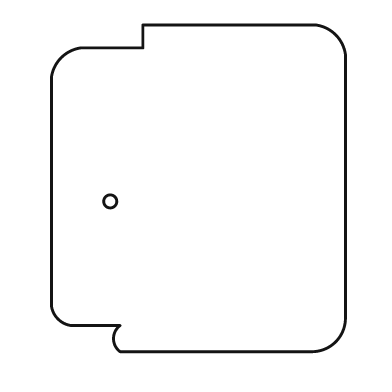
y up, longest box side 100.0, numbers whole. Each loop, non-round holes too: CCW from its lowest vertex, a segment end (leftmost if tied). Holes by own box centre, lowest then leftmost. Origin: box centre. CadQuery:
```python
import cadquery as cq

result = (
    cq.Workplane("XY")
    .moveTo(-24.0, -50.0)
    .lineTo(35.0, -50.0)
    .threePointArc((42.0, -47.0), (45.0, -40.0))
    .lineTo(45.0, 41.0)
    .threePointArc((42.0, 47.0), (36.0, 50.0))
    .lineTo(-17.0, 50.0)
    .lineTo(-17.0, 43.0)
    .lineTo(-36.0, 43.0)
    .threePointArc((-42.0, 40.0), (-45.0, 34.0))
    .lineTo(-45.0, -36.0)
    .threePointArc((-43.0, -40.0), (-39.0, -42.0))
    .lineTo(-24.0, -42.0)
    .threePointArc((-26.0, -46.0), (-24.0, -50.0))
    .close()
    .moveTo(-27.0, -4.0)
    .circle(2.0)
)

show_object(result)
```